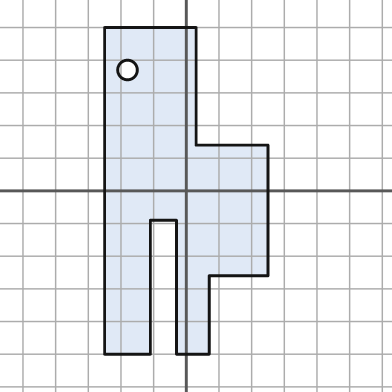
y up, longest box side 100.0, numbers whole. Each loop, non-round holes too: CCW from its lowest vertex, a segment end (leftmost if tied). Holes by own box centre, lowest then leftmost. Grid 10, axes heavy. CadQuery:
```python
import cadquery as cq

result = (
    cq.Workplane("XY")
    .moveTo(-25.0, -50.0)
    .lineTo(-11.0, -50.0)
    .lineTo(-11.0, -9.0)
    .lineTo(-3.0, -9.0)
    .lineTo(-3.0, -50.0)
    .lineTo(7.0, -50.0)
    .lineTo(7.0, -26.0)
    .lineTo(25.0, -26.0)
    .lineTo(25.0, 14.0)
    .lineTo(3.0, 14.0)
    .lineTo(3.0, 50.0)
    .lineTo(-25.0, 50.0)
    .close()
    .moveTo(-18.0, 37.0)
    .circle(3.0)
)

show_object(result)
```